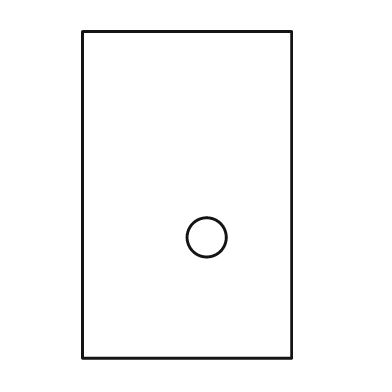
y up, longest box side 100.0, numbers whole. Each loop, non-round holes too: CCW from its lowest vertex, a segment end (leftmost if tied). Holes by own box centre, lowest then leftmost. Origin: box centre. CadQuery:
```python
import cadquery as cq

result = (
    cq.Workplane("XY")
    .moveTo(-32.0, -50.0)
    .lineTo(32.0, -50.0)
    .lineTo(32.0, 50.0)
    .lineTo(-32.0, 50.0)
    .close()
    .moveTo(6.0, -13.0)
    .circle(6.0)
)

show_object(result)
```